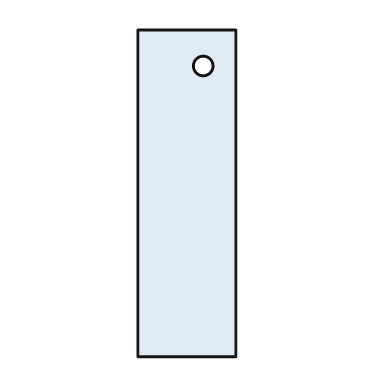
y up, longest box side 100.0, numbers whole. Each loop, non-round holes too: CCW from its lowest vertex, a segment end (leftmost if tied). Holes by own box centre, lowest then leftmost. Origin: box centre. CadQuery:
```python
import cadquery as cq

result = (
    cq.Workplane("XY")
    .moveTo(-15.0, -50.0)
    .lineTo(15.0, -50.0)
    .lineTo(15.0, 50.0)
    .lineTo(-15.0, 50.0)
    .close()
    .moveTo(5.0, 39.0)
    .circle(3.0)
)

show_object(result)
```